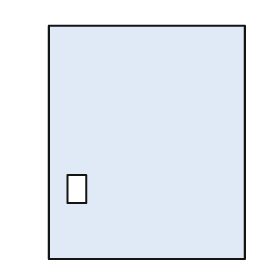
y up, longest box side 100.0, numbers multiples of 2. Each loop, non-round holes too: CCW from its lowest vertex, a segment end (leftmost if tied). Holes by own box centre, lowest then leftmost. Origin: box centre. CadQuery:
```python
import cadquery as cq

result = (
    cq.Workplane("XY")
    .moveTo(-42.0, -50.0)
    .lineTo(42.0, -50.0)
    .lineTo(42.0, 50.0)
    .lineTo(-42.0, 50.0)
    .close()
    .moveTo(-34.0, -26.0)
    .lineTo(-26.0, -26.0)
    .lineTo(-26.0, -14.0)
    .lineTo(-34.0, -14.0)
    .close()
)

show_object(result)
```